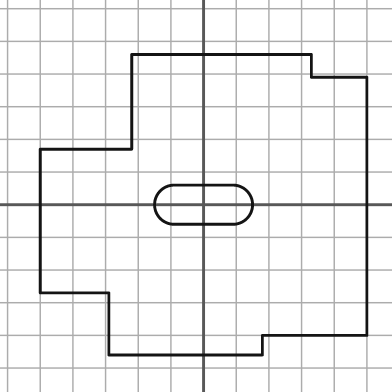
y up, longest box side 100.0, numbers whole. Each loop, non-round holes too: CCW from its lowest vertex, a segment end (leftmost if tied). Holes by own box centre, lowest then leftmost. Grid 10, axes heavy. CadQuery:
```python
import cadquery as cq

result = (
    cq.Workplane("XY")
    .moveTo(-29.0, -46.0)
    .lineTo(18.0, -46.0)
    .lineTo(18.0, -40.0)
    .lineTo(50.0, -40.0)
    .lineTo(50.0, 39.0)
    .lineTo(33.0, 39.0)
    .lineTo(33.0, 46.0)
    .lineTo(-22.0, 46.0)
    .lineTo(-22.0, 17.0)
    .lineTo(-50.0, 17.0)
    .lineTo(-50.0, -27.0)
    .lineTo(-29.0, -27.0)
    .close()
    .moveTo(-9.0, -6.0)
    .lineTo(9.0, -6.0)
    .threePointArc((15.0, 0.0), (9.0, 6.0))
    .lineTo(-9.0, 6.0)
    .threePointArc((-15.0, 0.0), (-9.0, -6.0))
    .close()
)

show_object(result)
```